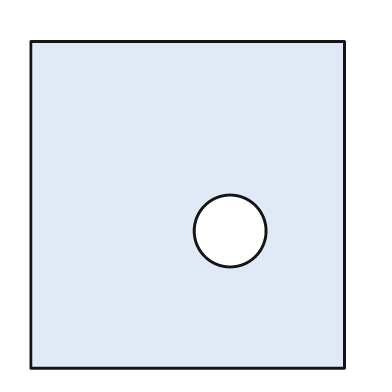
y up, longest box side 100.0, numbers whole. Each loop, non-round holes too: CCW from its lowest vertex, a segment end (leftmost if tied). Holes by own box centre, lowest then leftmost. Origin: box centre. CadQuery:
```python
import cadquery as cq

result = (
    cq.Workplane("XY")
    .moveTo(-48.0, -50.0)
    .lineTo(48.0, -50.0)
    .lineTo(48.0, 50.0)
    .lineTo(-48.0, 50.0)
    .close()
    .moveTo(13.0, -8.0)
    .circle(11.0)
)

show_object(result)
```